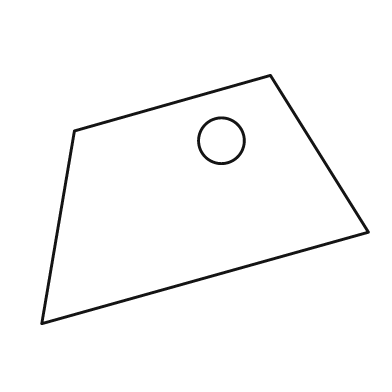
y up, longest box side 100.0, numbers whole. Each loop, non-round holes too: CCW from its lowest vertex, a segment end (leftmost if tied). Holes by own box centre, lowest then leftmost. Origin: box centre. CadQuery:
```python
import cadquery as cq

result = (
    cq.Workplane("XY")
    .moveTo(-50.0, -38.0)
    .lineTo(50.0, -10.0)
    .lineTo(20.0, 38.0)
    .lineTo(-40.0, 21.0)
    .close()
    .moveTo(5.0, 18.0)
    .circle(7.0)
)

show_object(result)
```